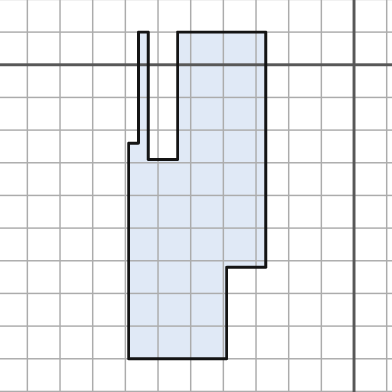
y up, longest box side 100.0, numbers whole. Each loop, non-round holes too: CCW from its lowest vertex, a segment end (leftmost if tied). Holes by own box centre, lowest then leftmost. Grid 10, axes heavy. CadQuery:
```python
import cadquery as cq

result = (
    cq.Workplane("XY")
    .moveTo(-69.0, -90.0)
    .lineTo(-39.0, -90.0)
    .lineTo(-39.0, -62.0)
    .lineTo(-27.0, -62.0)
    .lineTo(-27.0, 10.0)
    .lineTo(-54.0, 10.0)
    .lineTo(-54.0, -29.0)
    .lineTo(-63.0, -29.0)
    .lineTo(-63.0, 10.0)
    .lineTo(-66.0, 10.0)
    .lineTo(-66.0, -24.0)
    .lineTo(-69.0, -24.0)
    .close()
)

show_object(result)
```